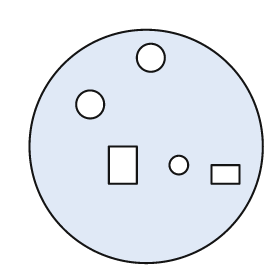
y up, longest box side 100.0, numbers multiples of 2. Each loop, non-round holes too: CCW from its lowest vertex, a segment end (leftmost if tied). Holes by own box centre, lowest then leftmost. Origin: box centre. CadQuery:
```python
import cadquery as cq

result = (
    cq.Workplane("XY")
    .moveTo(0.0, 0.0)
    .circle(50.0)
    .moveTo(28.0, -16.0)
    .lineTo(40.0, -16.0)
    .lineTo(40.0, -8.0)
    .lineTo(28.0, -8.0)
    .close()
    .moveTo(-16.0, -16.0)
    .lineTo(-4.0, -16.0)
    .lineTo(-4.0, 0.0)
    .lineTo(-16.0, 0.0)
    .close()
    .moveTo(14.0, -8.0)
    .circle(4.0)
    .moveTo(-24.0, 18.0)
    .circle(6.0)
    .moveTo(2.0, 38.0)
    .circle(6.0)
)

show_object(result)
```